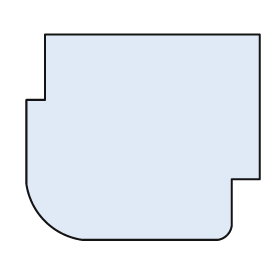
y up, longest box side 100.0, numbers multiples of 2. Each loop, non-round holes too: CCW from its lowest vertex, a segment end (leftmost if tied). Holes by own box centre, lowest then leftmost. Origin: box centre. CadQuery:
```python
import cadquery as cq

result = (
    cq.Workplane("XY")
    .moveTo(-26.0, -44.0)
    .lineTo(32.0, -44.0)
    .threePointArc((36.0, -42.0), (38.0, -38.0))
    .lineTo(38.0, -18.0)
    .lineTo(50.0, -18.0)
    .lineTo(50.0, 44.0)
    .lineTo(-42.0, 44.0)
    .lineTo(-42.0, 16.0)
    .lineTo(-50.0, 16.0)
    .lineTo(-50.0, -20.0)
    .threePointArc((-42.0, -36.0), (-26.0, -44.0))
    .close()
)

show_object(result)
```